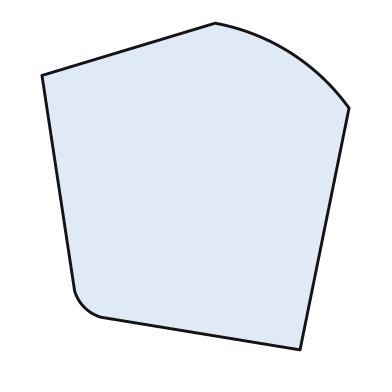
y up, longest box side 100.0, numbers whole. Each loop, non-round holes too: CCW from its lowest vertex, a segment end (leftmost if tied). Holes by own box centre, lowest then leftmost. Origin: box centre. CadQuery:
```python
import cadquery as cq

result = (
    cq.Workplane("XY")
    .moveTo(32.0, -50.0)
    .lineTo(47.0, 24.0)
    .threePointArc((29.0, 41.0), (6.0, 50.0))
    .lineTo(-47.0, 34.0)
    .lineTo(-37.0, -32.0)
    .threePointArc((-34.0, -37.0), (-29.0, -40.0))
    .close()
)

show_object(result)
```